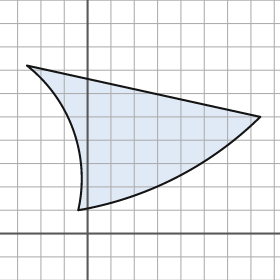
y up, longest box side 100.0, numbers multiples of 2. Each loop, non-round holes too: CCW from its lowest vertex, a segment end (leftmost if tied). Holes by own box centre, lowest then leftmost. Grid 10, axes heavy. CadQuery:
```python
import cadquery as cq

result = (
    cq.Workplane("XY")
    .moveTo(-4.0, 10.0)
    .threePointArc((38.0, 24.0), (74.0, 50.0))
    .lineTo(-26.0, 72.0)
    .threePointArc((-6.0, 44.0), (-4.0, 10.0))
    .close()
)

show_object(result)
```